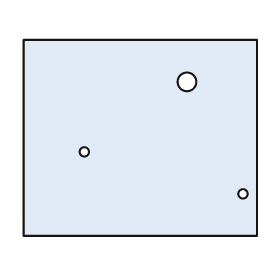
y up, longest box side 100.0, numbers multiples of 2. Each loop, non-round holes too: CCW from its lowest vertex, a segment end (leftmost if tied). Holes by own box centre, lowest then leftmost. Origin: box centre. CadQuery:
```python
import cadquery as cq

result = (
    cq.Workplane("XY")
    .moveTo(-50.0, -42.0)
    .lineTo(50.0, -42.0)
    .lineTo(50.0, 42.0)
    .lineTo(-50.0, 42.0)
    .close()
    .moveTo(44.0, -24.0)
    .circle(2.0)
    .moveTo(-24.0, -6.0)
    .circle(2.0)
    .moveTo(20.0, 24.0)
    .circle(4.0)
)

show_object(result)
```